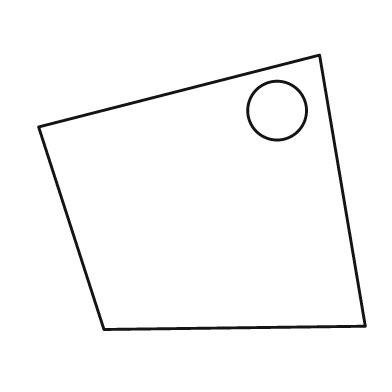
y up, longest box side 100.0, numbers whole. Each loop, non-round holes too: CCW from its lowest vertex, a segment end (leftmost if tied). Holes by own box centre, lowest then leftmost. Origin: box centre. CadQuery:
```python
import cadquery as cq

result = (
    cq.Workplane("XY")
    .moveTo(-30.0, -42.0)
    .lineTo(50.0, -41.0)
    .lineTo(36.0, 42.0)
    .lineTo(-50.0, 20.0)
    .close()
    .moveTo(23.0, 25.0)
    .circle(9.0)
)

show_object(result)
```